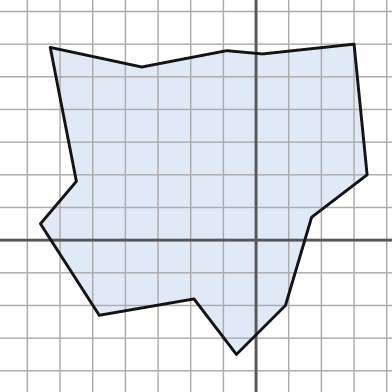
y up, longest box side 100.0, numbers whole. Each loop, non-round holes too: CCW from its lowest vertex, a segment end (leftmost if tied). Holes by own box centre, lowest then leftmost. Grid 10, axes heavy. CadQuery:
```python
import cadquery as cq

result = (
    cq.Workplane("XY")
    .moveTo(-6.0, -35.0)
    .lineTo(9.0, -20.0)
    .lineTo(17.0, 7.0)
    .lineTo(34.0, 20.0)
    .lineTo(30.0, 60.0)
    .lineTo(2.0, 57.0)
    .lineTo(-9.0, 58.0)
    .lineTo(-35.0, 53.0)
    .lineTo(-63.0, 59.0)
    .lineTo(-55.0, 18.0)
    .lineTo(-66.0, 5.0)
    .lineTo(-48.0, -23.0)
    .lineTo(-19.0, -18.0)
    .close()
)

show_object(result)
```